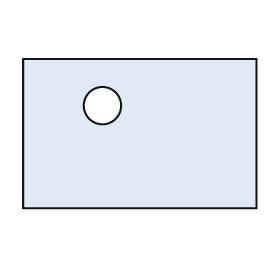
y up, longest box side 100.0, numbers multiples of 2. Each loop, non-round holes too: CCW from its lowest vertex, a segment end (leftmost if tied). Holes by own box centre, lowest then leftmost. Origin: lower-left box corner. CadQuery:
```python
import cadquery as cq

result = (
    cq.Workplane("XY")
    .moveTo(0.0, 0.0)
    .lineTo(100.0, 0.0)
    .lineTo(100.0, 64.0)
    .lineTo(0.0, 64.0)
    .close()
    .moveTo(34.0, 44.0)
    .circle(8.0)
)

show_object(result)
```